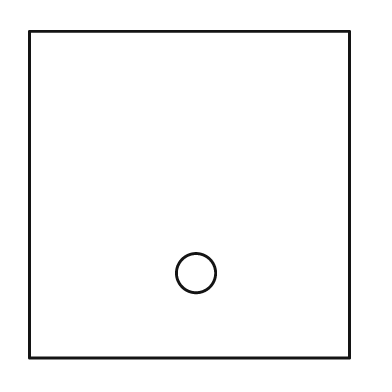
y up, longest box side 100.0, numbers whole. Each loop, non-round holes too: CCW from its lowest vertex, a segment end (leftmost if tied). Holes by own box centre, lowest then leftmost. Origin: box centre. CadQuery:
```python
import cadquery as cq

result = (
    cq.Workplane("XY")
    .moveTo(-49.0, -50.0)
    .lineTo(49.0, -50.0)
    .lineTo(49.0, 50.0)
    .lineTo(-49.0, 50.0)
    .close()
    .moveTo(2.0, -24.0)
    .circle(6.0)
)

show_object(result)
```